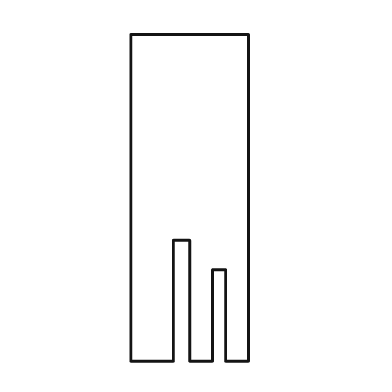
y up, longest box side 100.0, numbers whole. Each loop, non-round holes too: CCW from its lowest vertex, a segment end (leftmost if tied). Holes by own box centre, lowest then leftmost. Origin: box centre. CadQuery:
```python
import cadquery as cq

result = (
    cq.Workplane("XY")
    .moveTo(-18.0, -50.0)
    .lineTo(-5.0, -50.0)
    .lineTo(-5.0, -13.0)
    .lineTo(0.0, -13.0)
    .lineTo(0.0, -50.0)
    .lineTo(7.0, -50.0)
    .lineTo(7.0, -22.0)
    .lineTo(11.0, -22.0)
    .lineTo(11.0, -50.0)
    .lineTo(18.0, -50.0)
    .lineTo(18.0, 50.0)
    .lineTo(-18.0, 50.0)
    .close()
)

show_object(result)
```